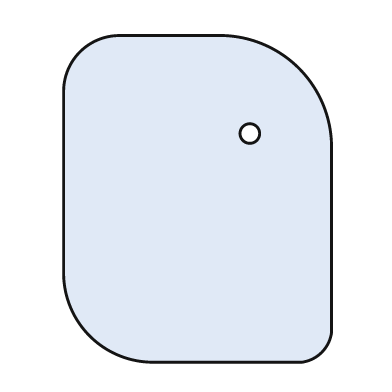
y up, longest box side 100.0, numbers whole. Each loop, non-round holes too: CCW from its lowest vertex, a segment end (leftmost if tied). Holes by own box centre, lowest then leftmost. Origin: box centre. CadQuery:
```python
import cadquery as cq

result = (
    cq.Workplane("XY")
    .moveTo(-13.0, -50.0)
    .lineTo(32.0, -50.0)
    .threePointArc((38.0, -47.0), (41.0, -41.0))
    .lineTo(41.0, 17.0)
    .threePointArc((31.0, 40.0), (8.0, 50.0))
    .lineTo(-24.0, 50.0)
    .threePointArc((-36.0, 45.0), (-41.0, 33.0))
    .lineTo(-41.0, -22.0)
    .threePointArc((-33.0, -42.0), (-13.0, -50.0))
    .close()
    .moveTo(16.0, 20.0)
    .circle(3.0)
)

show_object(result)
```